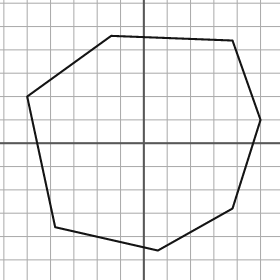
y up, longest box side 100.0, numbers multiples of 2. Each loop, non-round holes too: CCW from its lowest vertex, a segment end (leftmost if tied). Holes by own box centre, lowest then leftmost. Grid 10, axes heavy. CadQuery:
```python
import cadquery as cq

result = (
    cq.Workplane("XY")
    .moveTo(6.0, -46.0)
    .lineTo(38.0, -28.0)
    .lineTo(50.0, 10.0)
    .lineTo(38.0, 44.0)
    .lineTo(-14.0, 46.0)
    .lineTo(-50.0, 20.0)
    .lineTo(-38.0, -36.0)
    .close()
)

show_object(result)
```